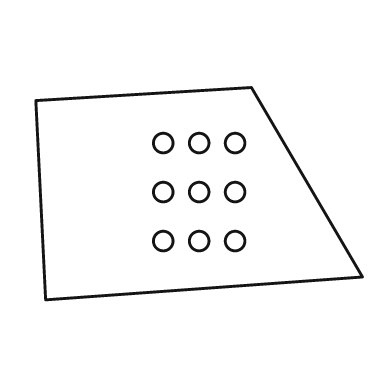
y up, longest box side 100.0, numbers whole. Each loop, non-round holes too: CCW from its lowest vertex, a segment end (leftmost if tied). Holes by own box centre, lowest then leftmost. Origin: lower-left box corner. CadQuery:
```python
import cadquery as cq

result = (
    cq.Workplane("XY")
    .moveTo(3.0, 0.0)
    .lineTo(100.0, 7.0)
    .lineTo(66.0, 65.0)
    .lineTo(0.0, 61.0)
    .close()
    .moveTo(39.0, 18.0)
    .circle(3.0)
    .moveTo(50.0, 18.0)
    .circle(3.0)
    .moveTo(61.0, 18.0)
    .circle(3.0)
    .moveTo(39.0, 33.0)
    .circle(3.0)
    .moveTo(50.0, 33.0)
    .circle(3.0)
    .moveTo(61.0, 33.0)
    .circle(3.0)
    .moveTo(39.0, 48.0)
    .circle(3.0)
    .moveTo(50.0, 48.0)
    .circle(3.0)
    .moveTo(61.0, 48.0)
    .circle(3.0)
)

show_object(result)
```